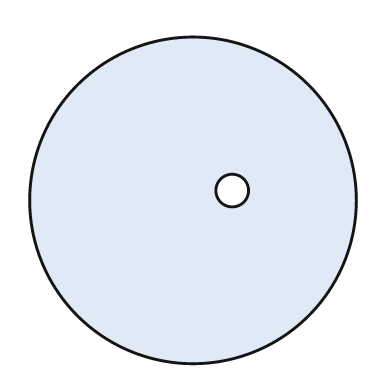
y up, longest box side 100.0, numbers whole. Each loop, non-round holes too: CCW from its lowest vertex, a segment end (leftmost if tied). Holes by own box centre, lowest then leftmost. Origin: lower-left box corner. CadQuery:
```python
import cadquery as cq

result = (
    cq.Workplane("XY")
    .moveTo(50.0, 50.0)
    .circle(50.0)
    .moveTo(62.0, 53.0)
    .circle(5.0)
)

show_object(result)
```